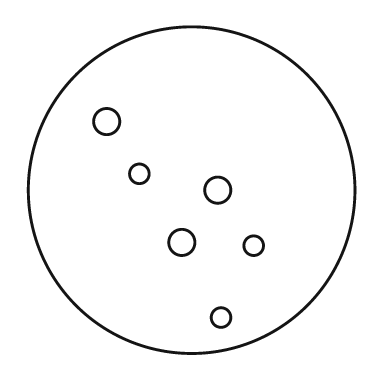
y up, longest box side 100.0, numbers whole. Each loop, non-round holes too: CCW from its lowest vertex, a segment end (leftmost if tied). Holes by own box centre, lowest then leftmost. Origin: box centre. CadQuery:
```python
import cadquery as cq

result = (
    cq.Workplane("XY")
    .moveTo(0.0, 0.0)
    .circle(50.0)
    .moveTo(9.0, -39.0)
    .circle(3.0)
    .moveTo(19.0, -17.0)
    .circle(3.0)
    .moveTo(-3.0, -16.0)
    .circle(4.0)
    .moveTo(8.0, 0.0)
    .circle(4.0)
    .moveTo(-16.0, 5.0)
    .circle(3.0)
    .moveTo(-26.0, 21.0)
    .circle(4.0)
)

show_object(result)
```